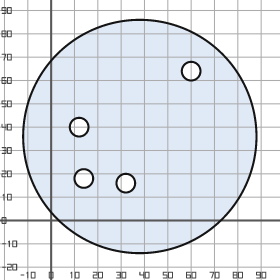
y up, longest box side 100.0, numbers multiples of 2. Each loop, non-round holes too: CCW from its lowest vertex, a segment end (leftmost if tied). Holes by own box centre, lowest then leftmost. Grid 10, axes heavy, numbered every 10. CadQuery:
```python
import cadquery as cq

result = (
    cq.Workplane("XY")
    .moveTo(38.0, 36.0)
    .circle(50.0)
    .moveTo(32.0, 16.0)
    .circle(4.0)
    .moveTo(14.0, 18.0)
    .circle(4.0)
    .moveTo(12.0, 40.0)
    .circle(4.0)
    .moveTo(60.0, 64.0)
    .circle(4.0)
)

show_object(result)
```